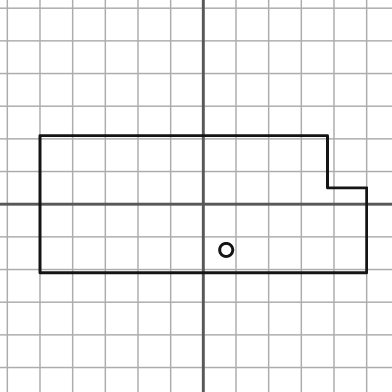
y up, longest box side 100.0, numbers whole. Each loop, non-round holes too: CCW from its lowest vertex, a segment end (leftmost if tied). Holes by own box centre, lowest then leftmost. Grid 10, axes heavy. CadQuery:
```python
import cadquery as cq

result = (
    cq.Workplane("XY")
    .moveTo(-50.0, -21.0)
    .lineTo(50.0, -21.0)
    .lineTo(50.0, 5.0)
    .lineTo(38.0, 5.0)
    .lineTo(38.0, 21.0)
    .lineTo(-50.0, 21.0)
    .close()
    .moveTo(7.0, -14.0)
    .circle(2.0)
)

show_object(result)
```